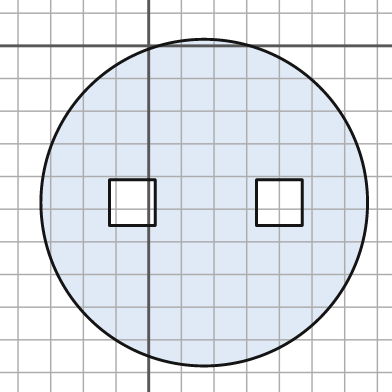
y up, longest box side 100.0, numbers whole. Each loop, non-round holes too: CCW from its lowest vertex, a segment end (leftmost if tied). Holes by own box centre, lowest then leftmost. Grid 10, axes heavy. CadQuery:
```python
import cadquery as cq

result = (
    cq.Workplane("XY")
    .moveTo(17.0, -48.0)
    .circle(50.0)
    .moveTo(-12.0, -55.0)
    .lineTo(2.0, -55.0)
    .lineTo(2.0, -41.0)
    .lineTo(-12.0, -41.0)
    .close()
    .moveTo(33.0, -55.0)
    .lineTo(47.0, -55.0)
    .lineTo(47.0, -41.0)
    .lineTo(33.0, -41.0)
    .close()
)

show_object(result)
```